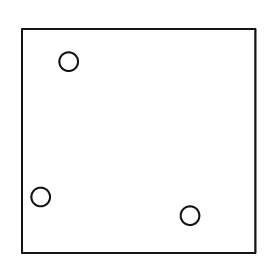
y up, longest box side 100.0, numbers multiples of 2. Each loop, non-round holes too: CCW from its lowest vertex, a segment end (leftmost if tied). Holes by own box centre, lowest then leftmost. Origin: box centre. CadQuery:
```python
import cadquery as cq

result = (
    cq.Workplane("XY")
    .moveTo(-50.0, -48.0)
    .lineTo(50.0, -48.0)
    .lineTo(50.0, 48.0)
    .lineTo(-50.0, 48.0)
    .close()
    .moveTo(22.0, -32.0)
    .circle(4.0)
    .moveTo(-42.0, -24.0)
    .circle(4.0)
    .moveTo(-30.0, 34.0)
    .circle(4.0)
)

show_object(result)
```